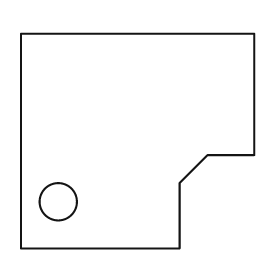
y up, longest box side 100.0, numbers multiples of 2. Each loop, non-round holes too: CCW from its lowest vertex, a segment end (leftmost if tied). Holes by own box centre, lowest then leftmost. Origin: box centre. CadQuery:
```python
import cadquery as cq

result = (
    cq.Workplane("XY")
    .moveTo(-50.0, -46.0)
    .lineTo(18.0, -46.0)
    .lineTo(18.0, -18.0)
    .lineTo(30.0, -6.0)
    .lineTo(50.0, -6.0)
    .lineTo(50.0, 46.0)
    .lineTo(-50.0, 46.0)
    .close()
    .moveTo(-34.0, -26.0)
    .circle(8.0)
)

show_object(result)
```